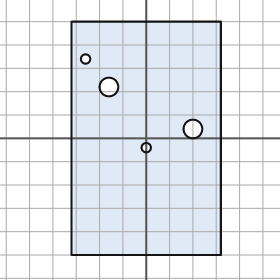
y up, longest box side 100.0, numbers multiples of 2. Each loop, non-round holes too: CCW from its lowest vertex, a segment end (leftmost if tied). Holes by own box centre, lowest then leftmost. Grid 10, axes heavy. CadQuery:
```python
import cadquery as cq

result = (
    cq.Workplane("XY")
    .moveTo(-32.0, -50.0)
    .lineTo(32.0, -50.0)
    .lineTo(32.0, 50.0)
    .lineTo(-32.0, 50.0)
    .close()
    .moveTo(0.0, -4.0)
    .circle(2.0)
    .moveTo(20.0, 4.0)
    .circle(4.0)
    .moveTo(-16.0, 22.0)
    .circle(4.0)
    .moveTo(-26.0, 34.0)
    .circle(2.0)
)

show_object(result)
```